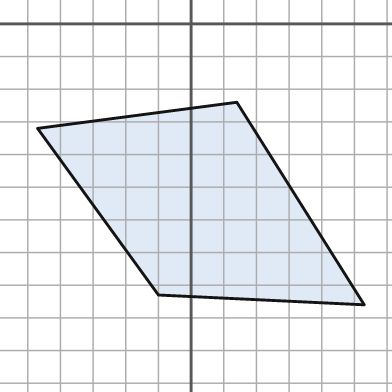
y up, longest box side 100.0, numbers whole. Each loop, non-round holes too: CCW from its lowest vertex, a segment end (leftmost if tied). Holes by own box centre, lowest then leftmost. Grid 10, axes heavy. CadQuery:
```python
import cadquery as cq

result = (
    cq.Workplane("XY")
    .moveTo(53.0, -86.0)
    .lineTo(14.0, -24.0)
    .lineTo(-47.0, -32.0)
    .lineTo(-10.0, -83.0)
    .close()
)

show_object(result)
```